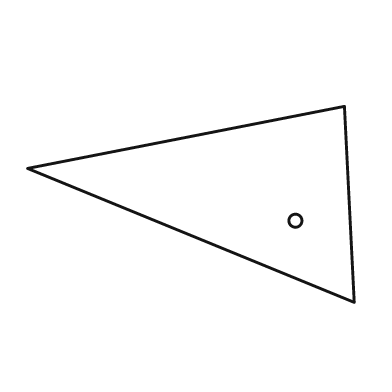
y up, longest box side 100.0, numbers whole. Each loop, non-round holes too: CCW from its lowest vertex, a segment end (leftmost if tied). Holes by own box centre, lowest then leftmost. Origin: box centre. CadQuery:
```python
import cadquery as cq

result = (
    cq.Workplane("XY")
    .moveTo(50.0, -30.0)
    .lineTo(47.0, 30.0)
    .lineTo(-50.0, 11.0)
    .close()
    .moveTo(32.0, -5.0)
    .circle(2.0)
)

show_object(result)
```